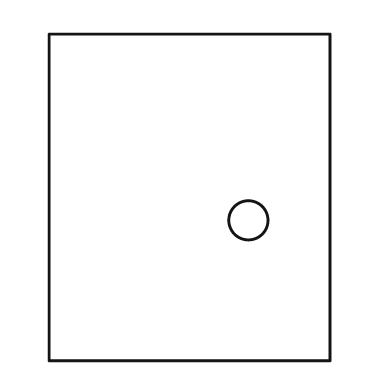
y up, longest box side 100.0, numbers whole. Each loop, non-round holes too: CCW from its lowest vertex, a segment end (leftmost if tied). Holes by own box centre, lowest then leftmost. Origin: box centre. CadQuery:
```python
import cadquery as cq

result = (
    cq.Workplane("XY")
    .moveTo(-43.0, -50.0)
    .lineTo(43.0, -50.0)
    .lineTo(43.0, 50.0)
    .lineTo(-43.0, 50.0)
    .close()
    .moveTo(18.0, -7.0)
    .circle(6.0)
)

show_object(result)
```